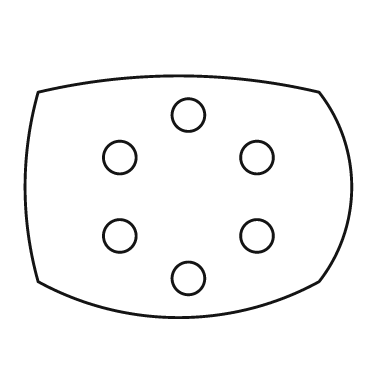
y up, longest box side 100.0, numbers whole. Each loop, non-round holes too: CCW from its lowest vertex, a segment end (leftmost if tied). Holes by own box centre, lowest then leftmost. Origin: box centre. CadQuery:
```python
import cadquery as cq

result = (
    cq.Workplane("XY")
    .moveTo(-46.0, -26.0)
    .threePointArc((-3.0, -37.0), (40.0, -26.0))
    .threePointArc((50.0, 3.0), (40.0, 32.0))
    .threePointArc((-3.0, 37.0), (-46.0, 32.0))
    .threePointArc((-50.0, 3.0), (-46.0, -26.0))
    .close()
    .moveTo(0.0, -25.0)
    .circle(5.0)
    .moveTo(-21.0, -12.0)
    .circle(5.0)
    .moveTo(21.0, -12.0)
    .circle(5.0)
    .moveTo(-21.0, 12.0)
    .circle(5.0)
    .moveTo(21.0, 12.0)
    .circle(5.0)
    .moveTo(0.0, 25.0)
    .circle(5.0)
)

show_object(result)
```